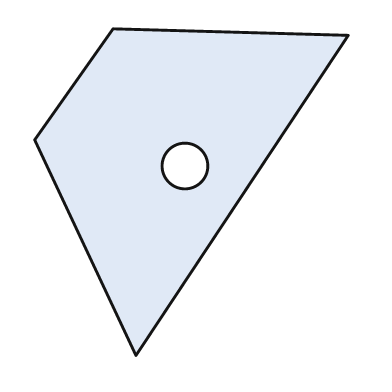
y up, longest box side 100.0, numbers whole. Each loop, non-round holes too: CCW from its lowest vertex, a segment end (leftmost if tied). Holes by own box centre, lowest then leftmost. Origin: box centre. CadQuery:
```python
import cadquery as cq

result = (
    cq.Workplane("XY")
    .moveTo(-17.0, -50.0)
    .lineTo(48.0, 48.0)
    .lineTo(-24.0, 50.0)
    .lineTo(-48.0, 16.0)
    .close()
    .moveTo(-2.0, 8.0)
    .circle(7.0)
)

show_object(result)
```